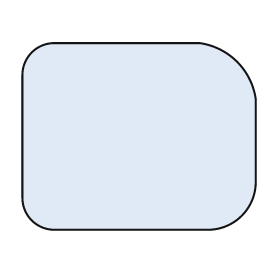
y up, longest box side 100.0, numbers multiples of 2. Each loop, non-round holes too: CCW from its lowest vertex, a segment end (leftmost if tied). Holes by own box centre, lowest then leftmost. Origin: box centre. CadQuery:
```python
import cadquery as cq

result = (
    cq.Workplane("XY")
    .moveTo(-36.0, -40.0)
    .lineTo(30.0, -40.0)
    .threePointArc((44.0, -34.0), (50.0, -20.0))
    .lineTo(50.0, 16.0)
    .threePointArc((42.0, 32.0), (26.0, 40.0))
    .lineTo(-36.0, 40.0)
    .threePointArc((-46.0, 36.0), (-50.0, 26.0))
    .lineTo(-50.0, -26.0)
    .threePointArc((-46.0, -36.0), (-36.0, -40.0))
    .close()
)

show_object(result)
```